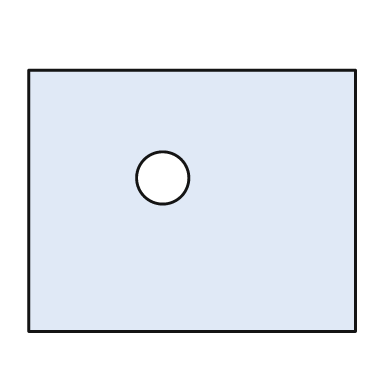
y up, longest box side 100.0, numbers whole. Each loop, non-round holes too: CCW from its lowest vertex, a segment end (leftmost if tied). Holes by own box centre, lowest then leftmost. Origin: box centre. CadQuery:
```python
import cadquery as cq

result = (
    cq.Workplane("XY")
    .moveTo(-50.0, -40.0)
    .lineTo(50.0, -40.0)
    .lineTo(50.0, 40.0)
    .lineTo(-50.0, 40.0)
    .close()
    .moveTo(-9.0, 7.0)
    .circle(8.0)
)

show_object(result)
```